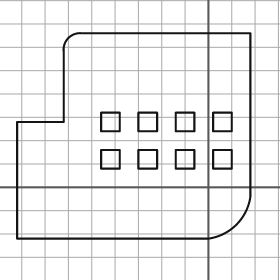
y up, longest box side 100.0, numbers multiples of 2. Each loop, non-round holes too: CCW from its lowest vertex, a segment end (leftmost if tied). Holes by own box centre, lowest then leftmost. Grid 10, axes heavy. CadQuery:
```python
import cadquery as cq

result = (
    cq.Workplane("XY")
    .moveTo(-82.0, -22.0)
    .lineTo(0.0, -22.0)
    .threePointArc((12.0, -16.0), (18.0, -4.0))
    .lineTo(18.0, 66.0)
    .lineTo(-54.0, 66.0)
    .threePointArc((-60.0, 64.0), (-62.0, 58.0))
    .lineTo(-62.0, 28.0)
    .lineTo(-82.0, 28.0)
    .close()
    .moveTo(-46.0, 8.0)
    .lineTo(-38.0, 8.0)
    .lineTo(-38.0, 16.0)
    .lineTo(-46.0, 16.0)
    .close()
    .moveTo(-30.0, 8.0)
    .lineTo(-22.0, 8.0)
    .lineTo(-22.0, 16.0)
    .lineTo(-30.0, 16.0)
    .close()
    .moveTo(-14.0, 8.0)
    .lineTo(-6.0, 8.0)
    .lineTo(-6.0, 16.0)
    .lineTo(-14.0, 16.0)
    .close()
    .moveTo(2.0, 8.0)
    .lineTo(10.0, 8.0)
    .lineTo(10.0, 16.0)
    .lineTo(2.0, 16.0)
    .close()
    .moveTo(-46.0, 24.0)
    .lineTo(-38.0, 24.0)
    .lineTo(-38.0, 32.0)
    .lineTo(-46.0, 32.0)
    .close()
    .moveTo(-30.0, 24.0)
    .lineTo(-22.0, 24.0)
    .lineTo(-22.0, 32.0)
    .lineTo(-30.0, 32.0)
    .close()
    .moveTo(-14.0, 24.0)
    .lineTo(-6.0, 24.0)
    .lineTo(-6.0, 32.0)
    .lineTo(-14.0, 32.0)
    .close()
    .moveTo(2.0, 24.0)
    .lineTo(10.0, 24.0)
    .lineTo(10.0, 32.0)
    .lineTo(2.0, 32.0)
    .close()
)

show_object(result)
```